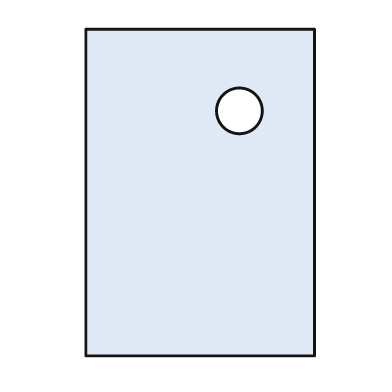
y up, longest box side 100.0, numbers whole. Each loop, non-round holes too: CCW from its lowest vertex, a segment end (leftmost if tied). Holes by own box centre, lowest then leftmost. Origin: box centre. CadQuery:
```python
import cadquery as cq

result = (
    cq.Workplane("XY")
    .moveTo(-35.0, -50.0)
    .lineTo(35.0, -50.0)
    .lineTo(35.0, 50.0)
    .lineTo(-35.0, 50.0)
    .close()
    .moveTo(12.0, 25.0)
    .circle(7.0)
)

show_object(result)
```